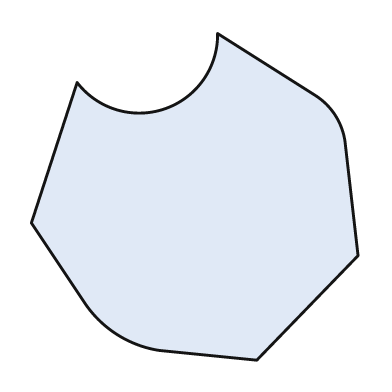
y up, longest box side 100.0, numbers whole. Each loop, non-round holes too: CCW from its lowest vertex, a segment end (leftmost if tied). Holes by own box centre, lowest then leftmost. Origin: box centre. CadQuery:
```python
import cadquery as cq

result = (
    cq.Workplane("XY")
    .moveTo(19.0, -50.0)
    .lineTo(50.0, -18.0)
    .lineTo(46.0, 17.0)
    .threePointArc((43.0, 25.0), (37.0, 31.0))
    .lineTo(7.0, 50.0)
    .threePointArc((-9.0, 27.0), (-36.0, 35.0))
    .lineTo(-50.0, -8.0)
    .lineTo(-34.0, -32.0)
    .threePointArc((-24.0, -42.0), (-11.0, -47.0))
    .close()
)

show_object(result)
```